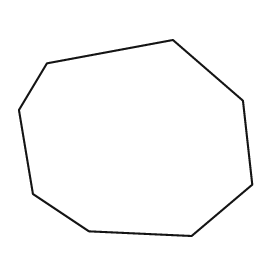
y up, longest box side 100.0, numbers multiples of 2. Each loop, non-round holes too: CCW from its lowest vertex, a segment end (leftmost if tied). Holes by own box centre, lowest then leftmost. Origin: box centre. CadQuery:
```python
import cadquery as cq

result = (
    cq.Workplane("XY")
    .moveTo(24.0, -42.0)
    .lineTo(50.0, -20.0)
    .lineTo(46.0, 16.0)
    .lineTo(16.0, 42.0)
    .lineTo(-38.0, 32.0)
    .lineTo(-50.0, 12.0)
    .lineTo(-44.0, -24.0)
    .lineTo(-20.0, -40.0)
    .close()
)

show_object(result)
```